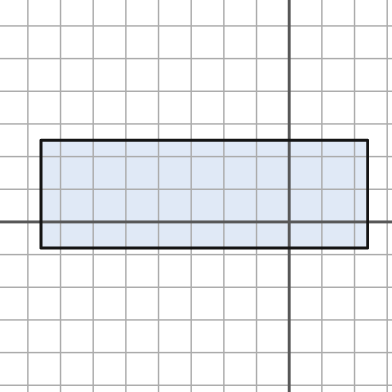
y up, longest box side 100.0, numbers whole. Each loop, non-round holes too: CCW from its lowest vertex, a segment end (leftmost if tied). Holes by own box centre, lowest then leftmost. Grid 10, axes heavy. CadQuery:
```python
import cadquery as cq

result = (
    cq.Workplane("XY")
    .moveTo(-76.0, -8.0)
    .lineTo(24.0, -8.0)
    .lineTo(24.0, 25.0)
    .lineTo(-76.0, 25.0)
    .close()
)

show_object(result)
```